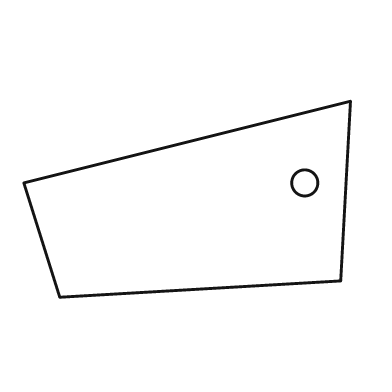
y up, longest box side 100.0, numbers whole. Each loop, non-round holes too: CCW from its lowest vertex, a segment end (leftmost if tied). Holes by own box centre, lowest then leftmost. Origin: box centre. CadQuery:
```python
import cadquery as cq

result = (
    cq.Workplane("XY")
    .moveTo(-39.0, -30.0)
    .lineTo(47.0, -25.0)
    .lineTo(50.0, 30.0)
    .lineTo(-50.0, 5.0)
    .close()
    .moveTo(36.0, 5.0)
    .circle(4.0)
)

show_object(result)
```